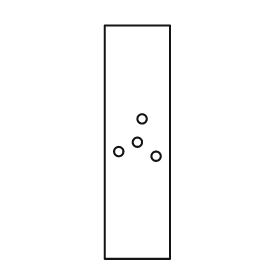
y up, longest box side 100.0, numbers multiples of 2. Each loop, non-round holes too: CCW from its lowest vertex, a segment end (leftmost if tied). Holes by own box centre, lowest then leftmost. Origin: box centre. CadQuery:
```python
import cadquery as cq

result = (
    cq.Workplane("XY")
    .moveTo(-14.0, -50.0)
    .lineTo(14.0, -50.0)
    .lineTo(14.0, 50.0)
    .lineTo(-14.0, 50.0)
    .close()
    .moveTo(8.0, -6.0)
    .circle(2.0)
    .moveTo(-8.0, -4.0)
    .circle(2.0)
    .moveTo(0.0, 0.0)
    .circle(2.0)
    .moveTo(2.0, 10.0)
    .circle(2.0)
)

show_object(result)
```